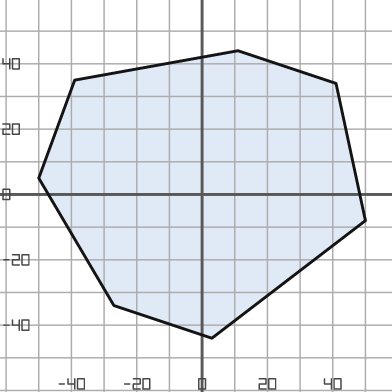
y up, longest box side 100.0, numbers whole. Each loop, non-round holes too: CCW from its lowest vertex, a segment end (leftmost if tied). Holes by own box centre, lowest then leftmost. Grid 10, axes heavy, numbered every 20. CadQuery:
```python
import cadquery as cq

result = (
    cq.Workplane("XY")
    .moveTo(3.0, -44.0)
    .lineTo(50.0, -8.0)
    .lineTo(41.0, 34.0)
    .lineTo(11.0, 44.0)
    .lineTo(-39.0, 35.0)
    .lineTo(-50.0, 5.0)
    .lineTo(-27.0, -34.0)
    .close()
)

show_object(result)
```